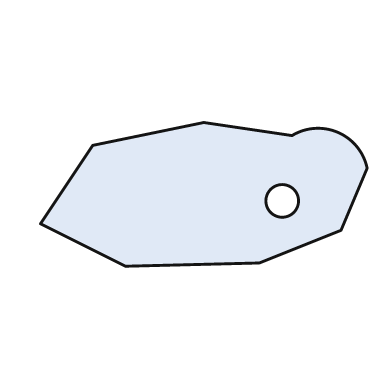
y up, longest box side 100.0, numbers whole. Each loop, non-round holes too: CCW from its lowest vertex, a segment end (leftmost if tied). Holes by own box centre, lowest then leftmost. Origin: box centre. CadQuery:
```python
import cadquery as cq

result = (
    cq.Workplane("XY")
    .moveTo(-24.0, -22.0)
    .lineTo(17.0, -21.0)
    .lineTo(42.0, -11.0)
    .lineTo(50.0, 8.0)
    .threePointArc((41.0, 19.0), (27.0, 18.0))
    .lineTo(0.0, 22.0)
    .lineTo(-34.0, 15.0)
    .lineTo(-50.0, -9.0)
    .close()
    .moveTo(24.0, -2.0)
    .circle(5.0)
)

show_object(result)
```